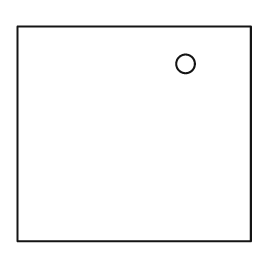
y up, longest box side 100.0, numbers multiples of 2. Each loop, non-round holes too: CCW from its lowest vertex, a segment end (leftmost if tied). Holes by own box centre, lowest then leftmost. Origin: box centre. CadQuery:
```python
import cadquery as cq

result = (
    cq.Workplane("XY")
    .moveTo(-50.0, -46.0)
    .lineTo(50.0, -46.0)
    .lineTo(50.0, 46.0)
    .lineTo(-50.0, 46.0)
    .close()
    .moveTo(22.0, 30.0)
    .circle(4.0)
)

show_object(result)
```